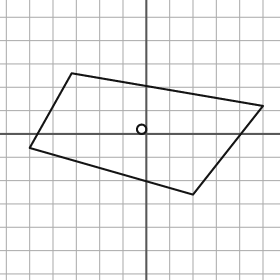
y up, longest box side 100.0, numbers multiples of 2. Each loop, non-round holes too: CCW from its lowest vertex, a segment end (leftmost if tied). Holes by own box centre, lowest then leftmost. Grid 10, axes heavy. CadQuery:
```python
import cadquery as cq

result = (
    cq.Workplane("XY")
    .moveTo(20.0, -26.0)
    .lineTo(50.0, 12.0)
    .lineTo(-32.0, 26.0)
    .lineTo(-50.0, -6.0)
    .close()
    .moveTo(-2.0, 2.0)
    .circle(2.0)
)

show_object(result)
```